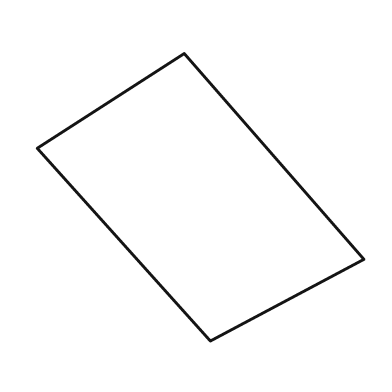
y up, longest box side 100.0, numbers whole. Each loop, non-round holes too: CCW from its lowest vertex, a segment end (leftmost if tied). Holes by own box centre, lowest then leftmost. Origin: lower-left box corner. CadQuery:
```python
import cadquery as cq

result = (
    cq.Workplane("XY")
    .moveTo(53.0, 0.0)
    .lineTo(100.0, 25.0)
    .lineTo(45.0, 88.0)
    .lineTo(0.0, 59.0)
    .close()
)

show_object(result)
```